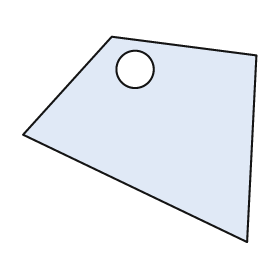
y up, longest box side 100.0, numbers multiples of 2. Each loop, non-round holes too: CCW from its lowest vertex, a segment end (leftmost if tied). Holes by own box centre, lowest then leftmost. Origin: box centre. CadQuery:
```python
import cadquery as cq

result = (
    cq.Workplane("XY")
    .moveTo(46.0, -44.0)
    .lineTo(50.0, 36.0)
    .lineTo(-12.0, 44.0)
    .lineTo(-50.0, 2.0)
    .close()
    .moveTo(-2.0, 30.0)
    .circle(8.0)
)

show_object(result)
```